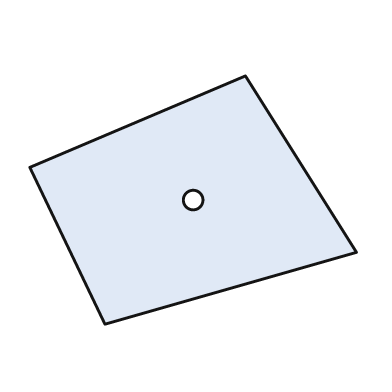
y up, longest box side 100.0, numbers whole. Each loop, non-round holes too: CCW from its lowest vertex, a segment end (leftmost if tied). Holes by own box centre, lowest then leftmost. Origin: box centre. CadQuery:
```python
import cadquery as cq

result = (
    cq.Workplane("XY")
    .moveTo(-27.0, -38.0)
    .lineTo(50.0, -16.0)
    .lineTo(16.0, 38.0)
    .lineTo(-50.0, 10.0)
    .close()
    .moveTo(0.0, 0.0)
    .circle(3.0)
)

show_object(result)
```